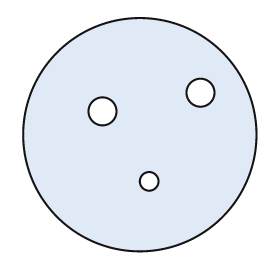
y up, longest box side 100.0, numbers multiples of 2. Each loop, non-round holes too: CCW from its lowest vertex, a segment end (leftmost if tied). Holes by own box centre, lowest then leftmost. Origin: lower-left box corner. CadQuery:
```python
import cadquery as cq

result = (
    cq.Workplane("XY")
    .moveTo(50.0, 50.0)
    .circle(50.0)
    .moveTo(54.0, 30.0)
    .circle(4.0)
    .moveTo(34.0, 60.0)
    .circle(6.0)
    .moveTo(76.0, 68.0)
    .circle(6.0)
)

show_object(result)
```